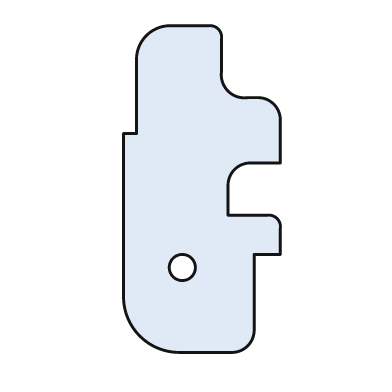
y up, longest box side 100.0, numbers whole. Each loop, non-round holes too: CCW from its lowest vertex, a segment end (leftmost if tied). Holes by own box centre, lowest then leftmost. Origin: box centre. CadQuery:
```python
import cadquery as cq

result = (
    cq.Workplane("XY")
    .moveTo(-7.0, -50.0)
    .lineTo(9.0, -50.0)
    .threePointArc((14.0, -48.0), (16.0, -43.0))
    .lineTo(16.0, -20.0)
    .lineTo(24.0, -20.0)
    .lineTo(24.0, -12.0)
    .threePointArc((23.0, -9.0), (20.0, -8.0))
    .lineTo(8.0, -8.0)
    .lineTo(8.0, 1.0)
    .threePointArc((10.0, 6.0), (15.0, 8.0))
    .lineTo(24.0, 8.0)
    .lineTo(24.0, 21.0)
    .threePointArc((22.0, 26.0), (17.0, 28.0))
    .lineTo(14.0, 28.0)
    .threePointArc((8.0, 30.0), (6.0, 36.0))
    .lineTo(6.0, 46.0)
    .threePointArc((5.0, 49.0), (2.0, 50.0))
    .lineTo(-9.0, 50.0)
    .threePointArc((-17.0, 47.0), (-20.0, 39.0))
    .lineTo(-20.0, 17.0)
    .lineTo(-24.0, 17.0)
    .lineTo(-24.0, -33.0)
    .threePointArc((-19.0, -45.0), (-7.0, -50.0))
    .close()
    .moveTo(-6.0, -24.0)
    .circle(4.0)
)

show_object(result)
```